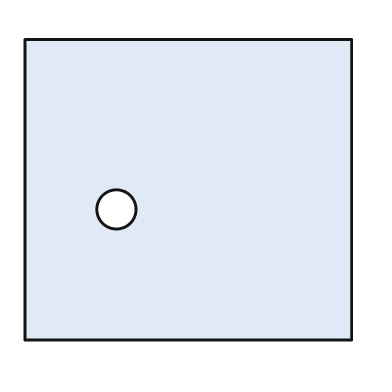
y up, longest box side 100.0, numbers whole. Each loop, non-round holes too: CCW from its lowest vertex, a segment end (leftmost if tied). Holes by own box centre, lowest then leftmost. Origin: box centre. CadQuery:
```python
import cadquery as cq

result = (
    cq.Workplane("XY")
    .moveTo(-50.0, -46.0)
    .lineTo(50.0, -46.0)
    .lineTo(50.0, 46.0)
    .lineTo(-50.0, 46.0)
    .close()
    .moveTo(-22.0, -6.0)
    .circle(6.0)
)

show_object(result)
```